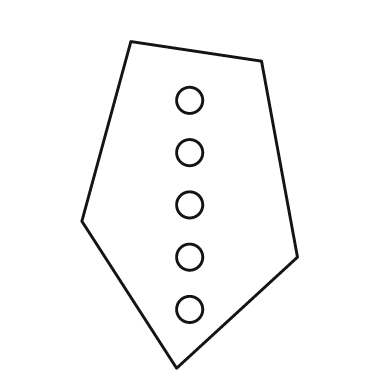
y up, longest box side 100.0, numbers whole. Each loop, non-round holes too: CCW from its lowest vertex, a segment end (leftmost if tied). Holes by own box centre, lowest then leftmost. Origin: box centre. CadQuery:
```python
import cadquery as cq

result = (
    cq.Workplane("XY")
    .moveTo(-4.0, -50.0)
    .lineTo(33.0, -16.0)
    .lineTo(22.0, 44.0)
    .lineTo(-18.0, 50.0)
    .lineTo(-33.0, -5.0)
    .close()
    .moveTo(0.0, -32.0)
    .circle(4.0)
    .moveTo(0.0, -16.0)
    .circle(4.0)
    .moveTo(0.0, 0.0)
    .circle(4.0)
    .moveTo(0.0, 16.0)
    .circle(4.0)
    .moveTo(0.0, 32.0)
    .circle(4.0)
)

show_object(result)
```